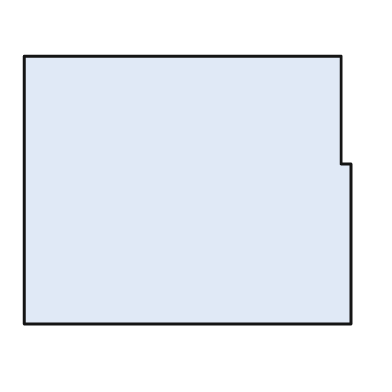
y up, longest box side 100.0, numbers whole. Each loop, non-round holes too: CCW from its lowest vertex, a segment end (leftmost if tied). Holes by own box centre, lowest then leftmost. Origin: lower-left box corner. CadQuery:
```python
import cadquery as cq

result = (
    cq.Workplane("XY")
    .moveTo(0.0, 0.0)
    .lineTo(100.0, 0.0)
    .lineTo(100.0, 49.0)
    .lineTo(97.0, 49.0)
    .lineTo(97.0, 82.0)
    .lineTo(0.0, 82.0)
    .close()
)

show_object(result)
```